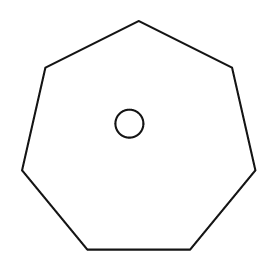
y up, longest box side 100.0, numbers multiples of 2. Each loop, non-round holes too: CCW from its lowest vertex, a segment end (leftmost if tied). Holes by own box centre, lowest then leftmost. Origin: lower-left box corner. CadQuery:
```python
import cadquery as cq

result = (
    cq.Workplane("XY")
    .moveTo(28.0, 0.0)
    .lineTo(72.0, 0.0)
    .lineTo(100.0, 34.0)
    .lineTo(90.0, 78.0)
    .lineTo(50.0, 98.0)
    .lineTo(10.0, 78.0)
    .lineTo(0.0, 34.0)
    .close()
    .moveTo(46.0, 54.0)
    .circle(6.0)
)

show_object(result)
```